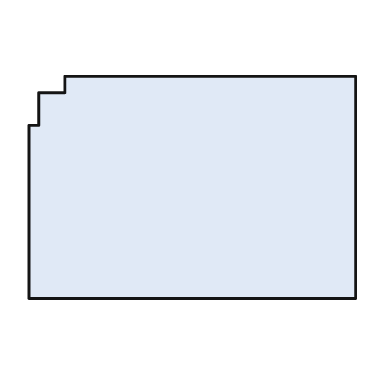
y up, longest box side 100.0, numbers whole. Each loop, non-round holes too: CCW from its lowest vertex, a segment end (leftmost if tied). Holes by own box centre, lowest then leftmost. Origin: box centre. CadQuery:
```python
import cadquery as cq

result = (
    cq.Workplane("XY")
    .moveTo(-50.0, -34.0)
    .lineTo(50.0, -34.0)
    .lineTo(50.0, 34.0)
    .lineTo(-39.0, 34.0)
    .lineTo(-39.0, 29.0)
    .lineTo(-47.0, 29.0)
    .lineTo(-47.0, 19.0)
    .lineTo(-50.0, 19.0)
    .close()
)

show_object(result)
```